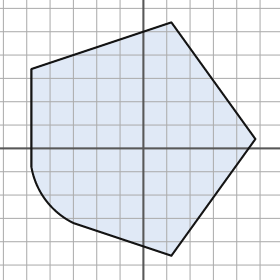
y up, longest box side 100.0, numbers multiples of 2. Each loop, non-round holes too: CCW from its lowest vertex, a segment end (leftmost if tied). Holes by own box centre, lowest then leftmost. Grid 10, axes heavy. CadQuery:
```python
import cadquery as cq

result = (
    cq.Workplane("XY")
    .moveTo(12.0, -46.0)
    .lineTo(48.0, 4.0)
    .lineTo(12.0, 54.0)
    .lineTo(-48.0, 34.0)
    .lineTo(-48.0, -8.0)
    .threePointArc((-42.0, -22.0), (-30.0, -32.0))
    .close()
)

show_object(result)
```